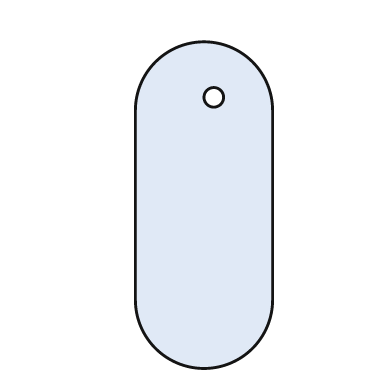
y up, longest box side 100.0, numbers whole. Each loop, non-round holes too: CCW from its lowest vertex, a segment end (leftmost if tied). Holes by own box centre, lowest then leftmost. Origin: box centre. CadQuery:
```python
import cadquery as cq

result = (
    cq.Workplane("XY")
    .moveTo(-21.0, -29.0)
    .threePointArc((0.0, -50.0), (21.0, -29.0))
    .lineTo(21.0, 29.0)
    .threePointArc((0.0, 50.0), (-21.0, 29.0))
    .close()
    .moveTo(3.0, 33.0)
    .circle(3.0)
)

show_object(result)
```